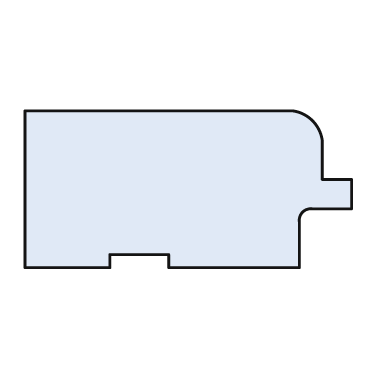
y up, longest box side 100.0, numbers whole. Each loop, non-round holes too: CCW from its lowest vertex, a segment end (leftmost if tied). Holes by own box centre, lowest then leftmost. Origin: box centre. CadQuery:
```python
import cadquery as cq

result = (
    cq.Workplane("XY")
    .moveTo(-50.0, -24.0)
    .lineTo(-24.0, -24.0)
    .lineTo(-24.0, -20.0)
    .lineTo(-6.0, -20.0)
    .lineTo(-6.0, -24.0)
    .lineTo(34.0, -24.0)
    .lineTo(34.0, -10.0)
    .threePointArc((35.0, -7.0), (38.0, -6.0))
    .lineTo(50.0, -6.0)
    .lineTo(50.0, 3.0)
    .lineTo(41.0, 3.0)
    .lineTo(41.0, 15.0)
    .threePointArc((38.0, 21.0), (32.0, 24.0))
    .lineTo(-50.0, 24.0)
    .close()
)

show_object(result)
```